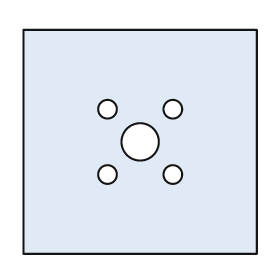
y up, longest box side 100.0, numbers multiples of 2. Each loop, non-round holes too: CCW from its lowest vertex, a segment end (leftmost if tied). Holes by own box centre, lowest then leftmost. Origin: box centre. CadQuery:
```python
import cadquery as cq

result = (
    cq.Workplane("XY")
    .moveTo(-50.0, -48.0)
    .lineTo(50.0, -48.0)
    .lineTo(50.0, 48.0)
    .lineTo(-50.0, 48.0)
    .close()
    .moveTo(-14.0, -14.0)
    .circle(4.0)
    .moveTo(14.0, -14.0)
    .circle(4.0)
    .moveTo(0.0, 0.0)
    .circle(8.0)
    .moveTo(-14.0, 14.0)
    .circle(4.0)
    .moveTo(14.0, 14.0)
    .circle(4.0)
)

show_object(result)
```